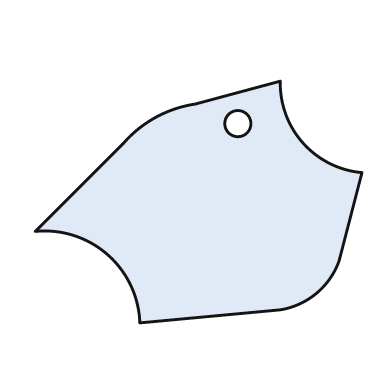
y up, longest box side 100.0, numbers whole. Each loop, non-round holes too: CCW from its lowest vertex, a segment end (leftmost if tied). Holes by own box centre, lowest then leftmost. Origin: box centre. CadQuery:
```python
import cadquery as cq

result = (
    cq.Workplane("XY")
    .moveTo(-18.0, -37.0)
    .lineTo(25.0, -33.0)
    .threePointArc((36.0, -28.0), (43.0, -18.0))
    .lineTo(50.0, 9.0)
    .threePointArc((32.0, 18.0), (25.0, 37.0))
    .lineTo(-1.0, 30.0)
    .threePointArc((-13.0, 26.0), (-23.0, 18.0))
    .lineTo(-50.0, -9.0)
    .threePointArc((-28.0, -16.0), (-18.0, -37.0))
    .close()
    .moveTo(12.0, 24.0)
    .circle(4.0)
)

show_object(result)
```